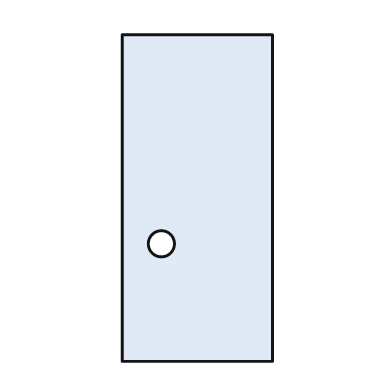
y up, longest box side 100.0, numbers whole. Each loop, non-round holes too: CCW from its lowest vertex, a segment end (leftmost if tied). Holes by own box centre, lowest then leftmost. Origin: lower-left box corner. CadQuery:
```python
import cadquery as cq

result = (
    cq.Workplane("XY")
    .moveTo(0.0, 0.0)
    .lineTo(46.0, 0.0)
    .lineTo(46.0, 100.0)
    .lineTo(0.0, 100.0)
    .close()
    .moveTo(12.0, 36.0)
    .circle(4.0)
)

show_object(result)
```